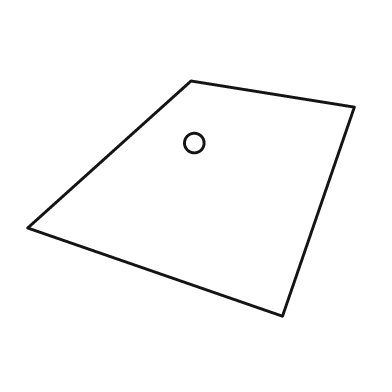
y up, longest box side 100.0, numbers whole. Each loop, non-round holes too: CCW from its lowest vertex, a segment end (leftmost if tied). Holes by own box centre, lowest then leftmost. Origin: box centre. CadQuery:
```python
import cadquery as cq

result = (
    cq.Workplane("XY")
    .moveTo(28.0, -36.0)
    .lineTo(50.0, 28.0)
    .lineTo(0.0, 36.0)
    .lineTo(-50.0, -9.0)
    .close()
    .moveTo(1.0, 17.0)
    .circle(3.0)
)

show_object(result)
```